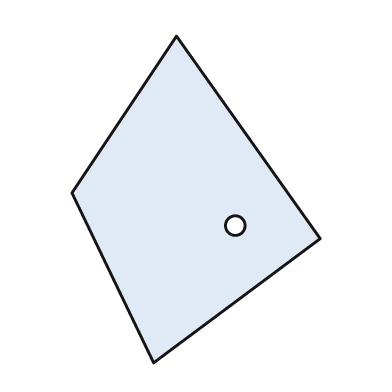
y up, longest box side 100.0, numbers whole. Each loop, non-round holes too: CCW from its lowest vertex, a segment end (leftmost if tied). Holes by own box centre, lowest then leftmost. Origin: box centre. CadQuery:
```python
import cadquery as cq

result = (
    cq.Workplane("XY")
    .moveTo(-13.0, -50.0)
    .lineTo(38.0, -12.0)
    .lineTo(-6.0, 50.0)
    .lineTo(-38.0, 2.0)
    .close()
    .moveTo(12.0, -8.0)
    .circle(3.0)
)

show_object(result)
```